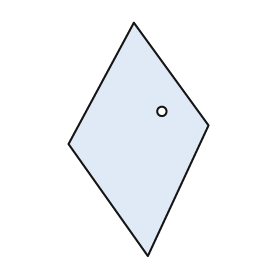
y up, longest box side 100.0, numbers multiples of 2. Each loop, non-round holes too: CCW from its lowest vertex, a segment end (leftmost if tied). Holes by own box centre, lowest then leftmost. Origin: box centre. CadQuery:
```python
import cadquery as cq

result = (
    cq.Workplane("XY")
    .moveTo(4.0, -50.0)
    .lineTo(30.0, 6.0)
    .lineTo(-2.0, 50.0)
    .lineTo(-30.0, -2.0)
    .close()
    .moveTo(10.0, 12.0)
    .circle(2.0)
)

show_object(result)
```